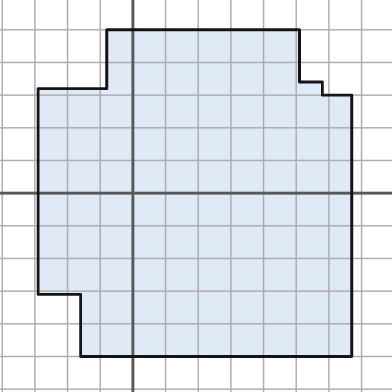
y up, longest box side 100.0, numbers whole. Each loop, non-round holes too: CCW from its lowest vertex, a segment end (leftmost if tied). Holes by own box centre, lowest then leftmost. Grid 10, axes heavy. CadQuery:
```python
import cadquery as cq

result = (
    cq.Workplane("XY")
    .moveTo(-16.0, -50.0)
    .lineTo(67.0, -50.0)
    .lineTo(67.0, 30.0)
    .lineTo(58.0, 30.0)
    .lineTo(58.0, 34.0)
    .lineTo(51.0, 34.0)
    .lineTo(51.0, 50.0)
    .lineTo(-8.0, 50.0)
    .lineTo(-8.0, 32.0)
    .lineTo(-29.0, 32.0)
    .lineTo(-29.0, -31.0)
    .lineTo(-16.0, -31.0)
    .close()
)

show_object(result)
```